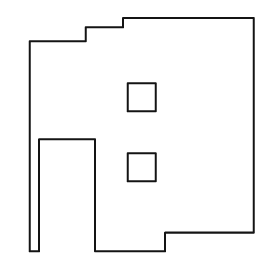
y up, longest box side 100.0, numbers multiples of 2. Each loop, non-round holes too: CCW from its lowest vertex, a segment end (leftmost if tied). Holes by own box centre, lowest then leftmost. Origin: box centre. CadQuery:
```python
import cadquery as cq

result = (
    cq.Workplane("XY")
    .moveTo(-48.0, -50.0)
    .lineTo(-44.0, -50.0)
    .lineTo(-44.0, -2.0)
    .lineTo(-20.0, -2.0)
    .lineTo(-20.0, -50.0)
    .lineTo(10.0, -50.0)
    .lineTo(10.0, -42.0)
    .lineTo(48.0, -42.0)
    .lineTo(48.0, 50.0)
    .lineTo(-8.0, 50.0)
    .lineTo(-8.0, 46.0)
    .lineTo(-24.0, 46.0)
    .lineTo(-24.0, 40.0)
    .lineTo(-48.0, 40.0)
    .close()
    .moveTo(-6.0, -20.0)
    .lineTo(6.0, -20.0)
    .lineTo(6.0, -8.0)
    .lineTo(-6.0, -8.0)
    .close()
    .moveTo(-6.0, 10.0)
    .lineTo(6.0, 10.0)
    .lineTo(6.0, 22.0)
    .lineTo(-6.0, 22.0)
    .close()
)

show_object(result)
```